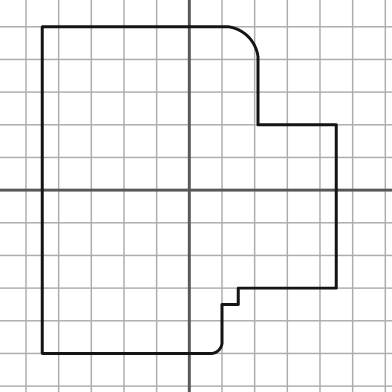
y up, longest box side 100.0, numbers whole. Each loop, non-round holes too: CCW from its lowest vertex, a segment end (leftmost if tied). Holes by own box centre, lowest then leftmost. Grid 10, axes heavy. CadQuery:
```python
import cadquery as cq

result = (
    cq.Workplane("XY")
    .moveTo(-45.0, -50.0)
    .lineTo(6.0, -50.0)
    .threePointArc((9.0, -49.0), (10.0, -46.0))
    .lineTo(10.0, -35.0)
    .lineTo(15.0, -35.0)
    .lineTo(15.0, -30.0)
    .lineTo(45.0, -30.0)
    .lineTo(45.0, 20.0)
    .lineTo(21.0, 20.0)
    .lineTo(21.0, 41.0)
    .threePointArc((18.0, 47.0), (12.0, 50.0))
    .lineTo(-45.0, 50.0)
    .close()
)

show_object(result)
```